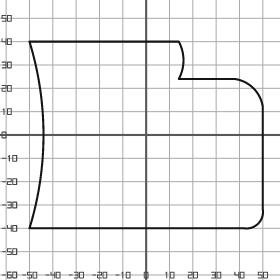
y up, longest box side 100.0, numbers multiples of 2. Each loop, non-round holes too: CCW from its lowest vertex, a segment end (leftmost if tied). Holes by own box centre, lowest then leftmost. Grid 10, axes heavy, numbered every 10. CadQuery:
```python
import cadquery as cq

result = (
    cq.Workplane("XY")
    .moveTo(-50.0, -40.0)
    .lineTo(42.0, -40.0)
    .threePointArc((48.0, -38.0), (50.0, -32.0))
    .lineTo(50.0, 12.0)
    .threePointArc((46.0, 20.0), (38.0, 24.0))
    .lineTo(14.0, 24.0)
    .threePointArc((16.0, 32.0), (14.0, 40.0))
    .lineTo(-50.0, 40.0)
    .threePointArc((-44.0, 0.0), (-50.0, -40.0))
    .close()
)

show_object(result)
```